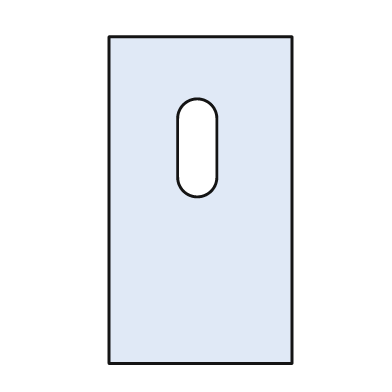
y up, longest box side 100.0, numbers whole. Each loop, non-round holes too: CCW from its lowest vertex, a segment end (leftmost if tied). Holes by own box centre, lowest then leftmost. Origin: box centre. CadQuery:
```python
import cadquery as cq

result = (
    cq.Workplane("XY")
    .moveTo(-28.0, -50.0)
    .lineTo(28.0, -50.0)
    .lineTo(28.0, 50.0)
    .lineTo(-28.0, 50.0)
    .close()
    .moveTo(-7.0, 7.0)
    .threePointArc((-1.0, 1.0), (5.0, 7.0))
    .lineTo(5.0, 25.0)
    .threePointArc((-1.0, 31.0), (-7.0, 25.0))
    .close()
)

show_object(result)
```